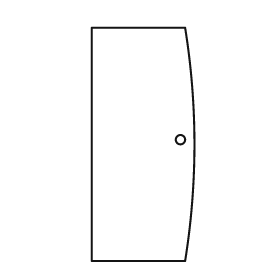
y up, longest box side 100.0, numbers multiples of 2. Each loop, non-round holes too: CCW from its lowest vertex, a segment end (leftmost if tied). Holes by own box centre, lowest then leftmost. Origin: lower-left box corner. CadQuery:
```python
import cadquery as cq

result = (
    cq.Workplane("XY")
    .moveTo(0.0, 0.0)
    .lineTo(40.0, 0.0)
    .threePointArc((44.0, 50.0), (40.0, 100.0))
    .lineTo(0.0, 100.0)
    .close()
    .moveTo(38.0, 52.0)
    .circle(2.0)
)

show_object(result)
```